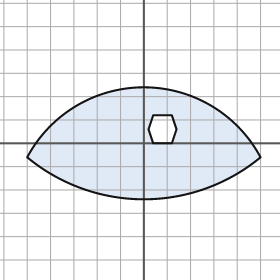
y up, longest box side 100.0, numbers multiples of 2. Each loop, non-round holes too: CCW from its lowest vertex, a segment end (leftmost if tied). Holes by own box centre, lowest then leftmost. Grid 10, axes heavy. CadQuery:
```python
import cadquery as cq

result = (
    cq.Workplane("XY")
    .moveTo(-50.0, -6.0)
    .threePointArc((0.0, -24.0), (50.0, -6.0))
    .threePointArc((0.0, 24.0), (-50.0, -6.0))
    .close()
    .moveTo(4.0, 0.0)
    .lineTo(12.0, 0.0)
    .lineTo(14.0, 6.0)
    .lineTo(12.0, 12.0)
    .lineTo(4.0, 12.0)
    .lineTo(2.0, 6.0)
    .close()
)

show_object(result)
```